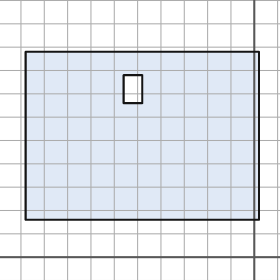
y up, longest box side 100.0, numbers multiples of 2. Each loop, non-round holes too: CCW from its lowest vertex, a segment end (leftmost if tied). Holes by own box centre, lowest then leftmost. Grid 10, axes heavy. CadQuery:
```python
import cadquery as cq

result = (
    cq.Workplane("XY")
    .moveTo(-98.0, 16.0)
    .lineTo(2.0, 16.0)
    .lineTo(2.0, 88.0)
    .lineTo(-98.0, 88.0)
    .close()
    .moveTo(-56.0, 66.0)
    .lineTo(-48.0, 66.0)
    .lineTo(-48.0, 78.0)
    .lineTo(-56.0, 78.0)
    .close()
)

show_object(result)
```